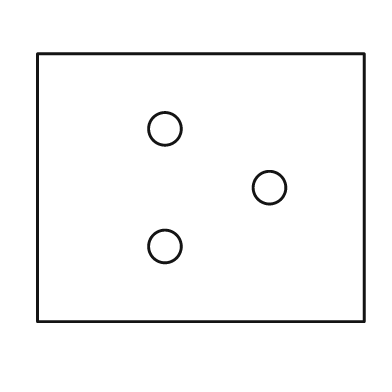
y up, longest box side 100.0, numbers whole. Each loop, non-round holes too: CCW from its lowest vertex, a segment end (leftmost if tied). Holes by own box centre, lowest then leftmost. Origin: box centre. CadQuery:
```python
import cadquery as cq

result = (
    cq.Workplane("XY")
    .moveTo(-50.0, -41.0)
    .lineTo(50.0, -41.0)
    .lineTo(50.0, 41.0)
    .lineTo(-50.0, 41.0)
    .close()
    .moveTo(-11.0, -18.0)
    .circle(5.0)
    .moveTo(21.0, 0.0)
    .circle(5.0)
    .moveTo(-11.0, 18.0)
    .circle(5.0)
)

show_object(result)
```